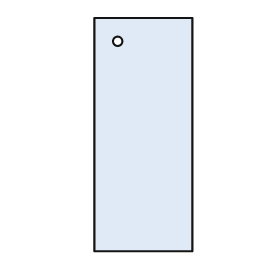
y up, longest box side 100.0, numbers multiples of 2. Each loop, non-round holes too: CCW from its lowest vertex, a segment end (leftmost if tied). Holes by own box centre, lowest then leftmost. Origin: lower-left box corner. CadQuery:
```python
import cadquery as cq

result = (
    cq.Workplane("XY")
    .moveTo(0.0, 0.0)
    .lineTo(42.0, 0.0)
    .lineTo(42.0, 100.0)
    .lineTo(0.0, 100.0)
    .close()
    .moveTo(10.0, 90.0)
    .circle(2.0)
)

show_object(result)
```